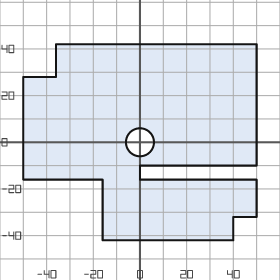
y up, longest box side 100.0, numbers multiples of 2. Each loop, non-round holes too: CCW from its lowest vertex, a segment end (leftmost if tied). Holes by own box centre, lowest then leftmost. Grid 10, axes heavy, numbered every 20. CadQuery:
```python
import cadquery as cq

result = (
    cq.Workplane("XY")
    .moveTo(-16.0, -42.0)
    .lineTo(40.0, -42.0)
    .lineTo(40.0, -32.0)
    .lineTo(50.0, -32.0)
    .lineTo(50.0, -16.0)
    .lineTo(0.0, -16.0)
    .lineTo(0.0, -10.0)
    .lineTo(50.0, -10.0)
    .lineTo(50.0, 42.0)
    .lineTo(-36.0, 42.0)
    .lineTo(-36.0, 28.0)
    .lineTo(-50.0, 28.0)
    .lineTo(-50.0, -16.0)
    .lineTo(-16.0, -16.0)
    .close()
    .moveTo(0.0, 0.0)
    .circle(6.0)
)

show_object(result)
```